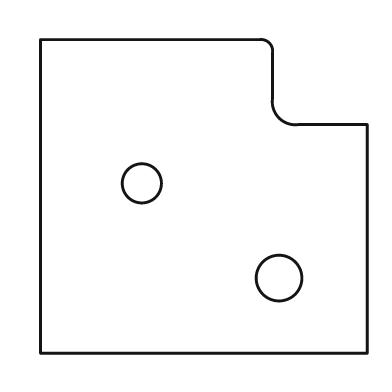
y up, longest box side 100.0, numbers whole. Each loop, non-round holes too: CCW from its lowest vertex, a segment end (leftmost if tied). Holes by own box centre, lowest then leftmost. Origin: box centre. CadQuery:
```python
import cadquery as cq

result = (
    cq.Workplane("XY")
    .moveTo(-50.0, -48.0)
    .lineTo(50.0, -48.0)
    .lineTo(50.0, 22.0)
    .lineTo(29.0, 22.0)
    .threePointArc((23.0, 24.0), (21.0, 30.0))
    .lineTo(21.0, 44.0)
    .threePointArc((20.0, 47.0), (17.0, 48.0))
    .lineTo(-50.0, 48.0)
    .close()
    .moveTo(23.0, -25.0)
    .circle(7.0)
    .moveTo(-19.0, 4.0)
    .circle(6.0)
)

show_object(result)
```